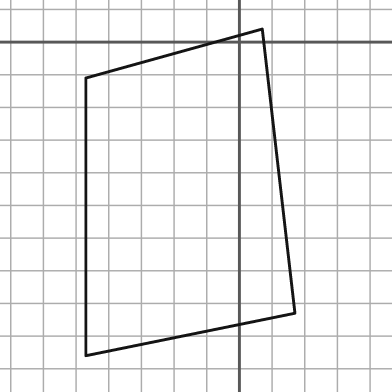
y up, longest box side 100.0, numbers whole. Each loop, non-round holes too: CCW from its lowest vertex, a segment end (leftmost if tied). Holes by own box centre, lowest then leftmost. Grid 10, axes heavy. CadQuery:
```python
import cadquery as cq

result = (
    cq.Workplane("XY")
    .moveTo(-47.0, -96.0)
    .lineTo(17.0, -83.0)
    .lineTo(7.0, 4.0)
    .lineTo(-47.0, -11.0)
    .close()
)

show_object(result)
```